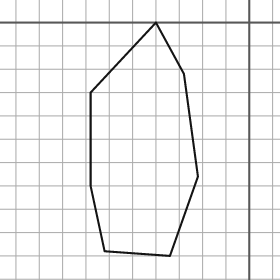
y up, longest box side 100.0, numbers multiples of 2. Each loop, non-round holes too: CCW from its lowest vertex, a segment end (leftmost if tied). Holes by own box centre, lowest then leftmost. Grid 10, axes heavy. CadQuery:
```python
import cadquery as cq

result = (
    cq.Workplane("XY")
    .moveTo(-34.0, -100.0)
    .lineTo(-22.0, -66.0)
    .lineTo(-28.0, -22.0)
    .lineTo(-40.0, 0.0)
    .lineTo(-68.0, -30.0)
    .lineTo(-68.0, -70.0)
    .lineTo(-62.0, -98.0)
    .close()
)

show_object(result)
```